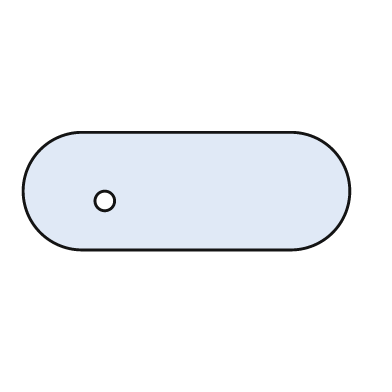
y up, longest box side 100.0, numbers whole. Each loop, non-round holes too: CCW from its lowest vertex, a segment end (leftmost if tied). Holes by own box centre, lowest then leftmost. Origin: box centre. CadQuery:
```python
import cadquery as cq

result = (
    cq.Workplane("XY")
    .moveTo(-32.0, -18.0)
    .lineTo(32.0, -18.0)
    .threePointArc((50.0, 0.0), (32.0, 18.0))
    .lineTo(-32.0, 18.0)
    .threePointArc((-50.0, 0.0), (-32.0, -18.0))
    .close()
    .moveTo(-25.0, -3.0)
    .circle(3.0)
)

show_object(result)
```